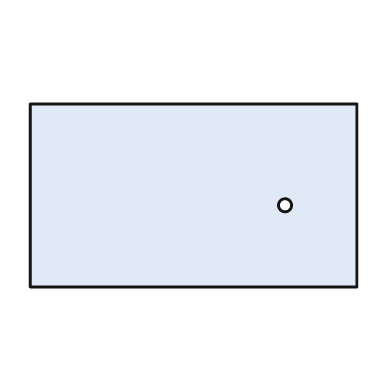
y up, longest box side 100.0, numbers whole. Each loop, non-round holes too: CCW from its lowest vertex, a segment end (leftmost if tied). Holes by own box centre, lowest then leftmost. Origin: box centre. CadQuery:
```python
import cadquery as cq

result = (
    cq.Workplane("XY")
    .moveTo(-50.0, -28.0)
    .lineTo(50.0, -28.0)
    .lineTo(50.0, 28.0)
    .lineTo(-50.0, 28.0)
    .close()
    .moveTo(28.0, -3.0)
    .circle(2.0)
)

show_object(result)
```